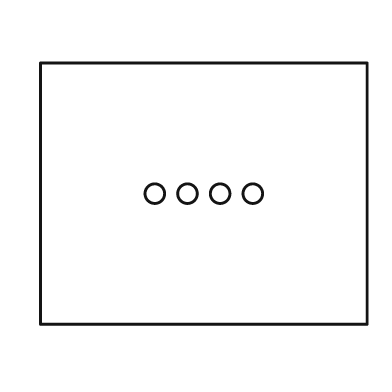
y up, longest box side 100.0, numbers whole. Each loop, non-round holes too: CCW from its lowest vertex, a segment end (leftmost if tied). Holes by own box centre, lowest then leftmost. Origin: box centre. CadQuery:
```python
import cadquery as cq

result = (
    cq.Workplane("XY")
    .moveTo(-50.0, -40.0)
    .lineTo(50.0, -40.0)
    .lineTo(50.0, 40.0)
    .lineTo(-50.0, 40.0)
    .close()
    .moveTo(-15.0, 0.0)
    .circle(3.0)
    .moveTo(-5.0, 0.0)
    .circle(3.0)
    .moveTo(5.0, 0.0)
    .circle(3.0)
    .moveTo(15.0, 0.0)
    .circle(3.0)
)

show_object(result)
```